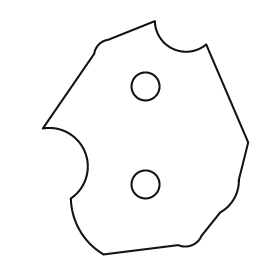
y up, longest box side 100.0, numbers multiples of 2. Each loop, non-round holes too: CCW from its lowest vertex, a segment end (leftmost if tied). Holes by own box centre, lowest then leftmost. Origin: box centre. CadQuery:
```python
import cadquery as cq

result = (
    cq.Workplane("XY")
    .moveTo(-18.0, -50.0)
    .lineTo(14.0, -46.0)
    .threePointArc((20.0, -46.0), (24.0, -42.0))
    .lineTo(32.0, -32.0)
    .threePointArc((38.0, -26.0), (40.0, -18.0))
    .lineTo(44.0, -2.0)
    .lineTo(26.0, 40.0)
    .threePointArc((12.0, 38.0), (4.0, 50.0))
    .lineTo(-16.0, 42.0)
    .threePointArc((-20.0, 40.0), (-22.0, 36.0))
    .lineTo(-44.0, 4.0)
    .threePointArc((-26.0, -6.0), (-32.0, -26.0))
    .threePointArc((-28.0, -40.0), (-18.0, -50.0))
    .close()
    .moveTo(0.0, -20.0)
    .circle(6.0)
    .moveTo(0.0, 22.0)
    .circle(6.0)
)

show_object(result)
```